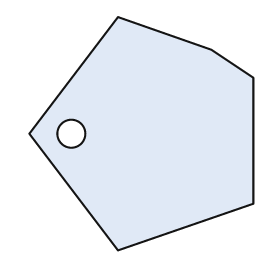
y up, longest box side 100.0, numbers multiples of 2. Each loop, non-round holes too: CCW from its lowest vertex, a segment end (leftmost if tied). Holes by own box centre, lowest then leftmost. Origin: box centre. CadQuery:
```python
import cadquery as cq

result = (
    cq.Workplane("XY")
    .moveTo(-10.0, -50.0)
    .lineTo(48.0, -30.0)
    .lineTo(48.0, 24.0)
    .lineTo(30.0, 36.0)
    .lineTo(-10.0, 50.0)
    .lineTo(-48.0, 0.0)
    .close()
    .moveTo(-30.0, 0.0)
    .circle(6.0)
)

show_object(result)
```